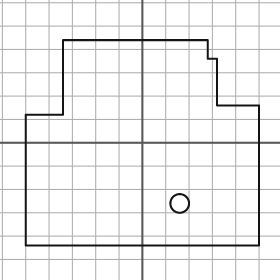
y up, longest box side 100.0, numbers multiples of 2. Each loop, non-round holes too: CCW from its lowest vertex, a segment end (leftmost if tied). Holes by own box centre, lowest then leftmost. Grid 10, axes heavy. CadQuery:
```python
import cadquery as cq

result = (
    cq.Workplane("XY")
    .moveTo(-50.0, -44.0)
    .lineTo(50.0, -44.0)
    .lineTo(50.0, 16.0)
    .lineTo(32.0, 16.0)
    .lineTo(32.0, 36.0)
    .lineTo(28.0, 36.0)
    .lineTo(28.0, 44.0)
    .lineTo(-34.0, 44.0)
    .lineTo(-34.0, 12.0)
    .lineTo(-50.0, 12.0)
    .close()
    .moveTo(16.0, -26.0)
    .circle(4.0)
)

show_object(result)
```